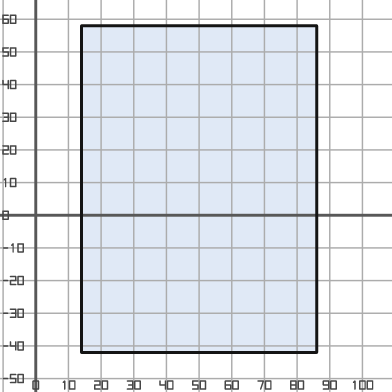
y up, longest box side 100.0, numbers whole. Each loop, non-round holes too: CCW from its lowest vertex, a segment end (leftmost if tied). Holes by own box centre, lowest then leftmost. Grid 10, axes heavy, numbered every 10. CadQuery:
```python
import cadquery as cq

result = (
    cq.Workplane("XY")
    .moveTo(14.0, -42.0)
    .lineTo(86.0, -42.0)
    .lineTo(86.0, 58.0)
    .lineTo(14.0, 58.0)
    .close()
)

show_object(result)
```